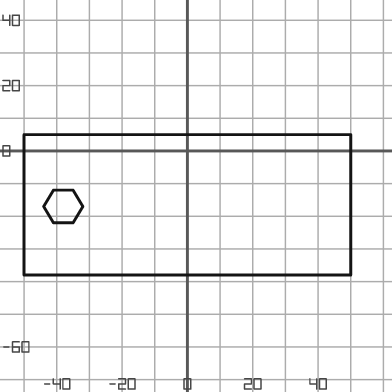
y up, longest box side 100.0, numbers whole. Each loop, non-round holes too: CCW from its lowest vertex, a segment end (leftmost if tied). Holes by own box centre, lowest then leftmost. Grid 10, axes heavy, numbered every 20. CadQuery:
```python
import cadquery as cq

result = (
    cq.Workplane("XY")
    .moveTo(-50.0, -38.0)
    .lineTo(50.0, -38.0)
    .lineTo(50.0, 5.0)
    .lineTo(-50.0, 5.0)
    .close()
    .moveTo(-41.0, -22.0)
    .lineTo(-35.0, -22.0)
    .lineTo(-32.0, -17.0)
    .lineTo(-35.0, -12.0)
    .lineTo(-41.0, -12.0)
    .lineTo(-44.0, -17.0)
    .close()
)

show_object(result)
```